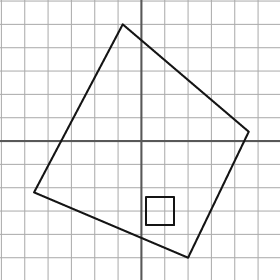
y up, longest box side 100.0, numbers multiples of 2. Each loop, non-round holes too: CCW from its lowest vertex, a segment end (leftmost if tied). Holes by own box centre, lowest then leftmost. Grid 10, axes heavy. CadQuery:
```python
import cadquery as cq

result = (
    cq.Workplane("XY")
    .moveTo(20.0, -50.0)
    .lineTo(46.0, 4.0)
    .lineTo(-8.0, 50.0)
    .lineTo(-46.0, -22.0)
    .close()
    .moveTo(2.0, -36.0)
    .lineTo(14.0, -36.0)
    .lineTo(14.0, -24.0)
    .lineTo(2.0, -24.0)
    .close()
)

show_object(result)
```